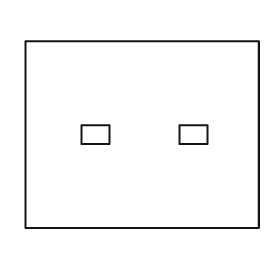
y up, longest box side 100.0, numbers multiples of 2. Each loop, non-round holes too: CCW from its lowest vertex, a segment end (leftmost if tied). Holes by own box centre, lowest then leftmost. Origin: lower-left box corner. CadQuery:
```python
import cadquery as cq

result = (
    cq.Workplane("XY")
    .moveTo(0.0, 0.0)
    .lineTo(100.0, 0.0)
    .lineTo(100.0, 80.0)
    .lineTo(0.0, 80.0)
    .close()
    .moveTo(24.0, 36.0)
    .lineTo(36.0, 36.0)
    .lineTo(36.0, 44.0)
    .lineTo(24.0, 44.0)
    .close()
    .moveTo(66.0, 36.0)
    .lineTo(78.0, 36.0)
    .lineTo(78.0, 44.0)
    .lineTo(66.0, 44.0)
    .close()
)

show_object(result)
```